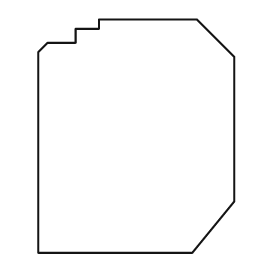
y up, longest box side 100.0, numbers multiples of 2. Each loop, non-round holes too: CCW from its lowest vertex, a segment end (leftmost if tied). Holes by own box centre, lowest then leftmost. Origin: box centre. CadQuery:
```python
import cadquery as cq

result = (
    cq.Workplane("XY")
    .moveTo(-42.0, -50.0)
    .lineTo(24.0, -50.0)
    .lineTo(42.0, -28.0)
    .lineTo(42.0, 34.0)
    .lineTo(26.0, 50.0)
    .lineTo(-16.0, 50.0)
    .lineTo(-16.0, 46.0)
    .lineTo(-26.0, 46.0)
    .lineTo(-26.0, 40.0)
    .lineTo(-38.0, 40.0)
    .lineTo(-42.0, 36.0)
    .close()
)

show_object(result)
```